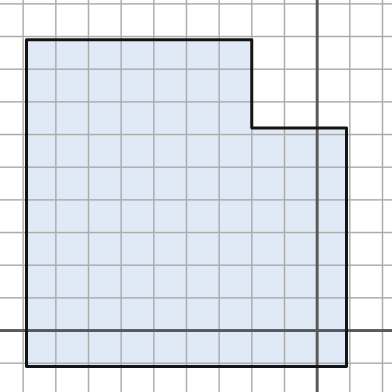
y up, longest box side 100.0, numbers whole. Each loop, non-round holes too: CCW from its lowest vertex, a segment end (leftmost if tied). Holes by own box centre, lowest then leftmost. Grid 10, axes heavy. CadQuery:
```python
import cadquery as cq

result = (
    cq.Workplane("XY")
    .moveTo(-89.0, -11.0)
    .lineTo(9.0, -11.0)
    .lineTo(9.0, 62.0)
    .lineTo(-20.0, 62.0)
    .lineTo(-20.0, 89.0)
    .lineTo(-89.0, 89.0)
    .close()
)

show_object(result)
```